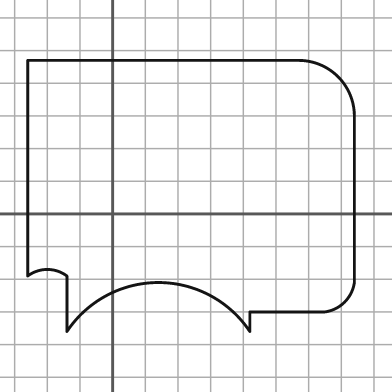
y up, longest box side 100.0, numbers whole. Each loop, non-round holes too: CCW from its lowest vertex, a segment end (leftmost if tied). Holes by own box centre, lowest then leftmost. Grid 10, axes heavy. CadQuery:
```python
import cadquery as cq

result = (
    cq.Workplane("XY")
    .moveTo(-14.0, -36.0)
    .threePointArc((14.0, -21.0), (42.0, -36.0))
    .lineTo(42.0, -30.0)
    .lineTo(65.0, -30.0)
    .threePointArc((71.0, -27.0), (74.0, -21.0))
    .lineTo(74.0, 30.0)
    .threePointArc((69.0, 42.0), (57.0, 47.0))
    .lineTo(-26.0, 47.0)
    .lineTo(-26.0, -19.0)
    .threePointArc((-20.0, -17.0), (-14.0, -19.0))
    .close()
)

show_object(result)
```